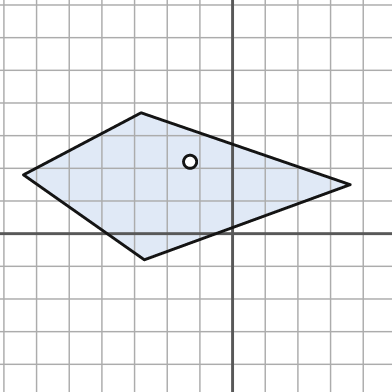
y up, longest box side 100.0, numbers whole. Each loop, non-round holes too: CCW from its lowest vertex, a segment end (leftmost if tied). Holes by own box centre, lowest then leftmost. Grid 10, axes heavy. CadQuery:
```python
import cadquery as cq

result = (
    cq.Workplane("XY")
    .moveTo(-27.0, -8.0)
    .lineTo(36.0, 15.0)
    .lineTo(-28.0, 37.0)
    .lineTo(-64.0, 18.0)
    .close()
    .moveTo(-13.0, 22.0)
    .circle(2.0)
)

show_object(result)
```